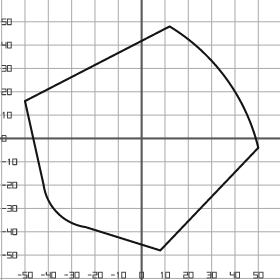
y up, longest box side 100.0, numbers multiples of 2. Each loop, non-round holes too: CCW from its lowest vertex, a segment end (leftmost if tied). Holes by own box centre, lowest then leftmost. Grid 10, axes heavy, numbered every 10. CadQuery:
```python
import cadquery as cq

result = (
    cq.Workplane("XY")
    .moveTo(8.0, -48.0)
    .lineTo(50.0, -4.0)
    .threePointArc((36.0, 26.0), (12.0, 48.0))
    .lineTo(-50.0, 16.0)
    .lineTo(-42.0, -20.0)
    .threePointArc((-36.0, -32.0), (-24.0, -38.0))
    .close()
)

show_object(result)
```